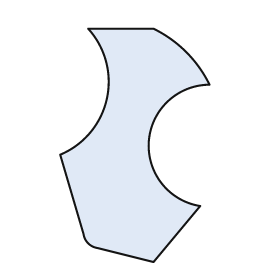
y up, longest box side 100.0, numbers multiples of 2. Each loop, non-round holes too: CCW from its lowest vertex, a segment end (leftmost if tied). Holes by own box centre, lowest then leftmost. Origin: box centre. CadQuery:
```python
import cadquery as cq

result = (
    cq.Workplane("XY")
    .moveTo(8.0, -50.0)
    .lineTo(28.0, -26.0)
    .threePointArc((6.0, 2.0), (32.0, 26.0))
    .threePointArc((22.0, 40.0), (8.0, 50.0))
    .lineTo(-20.0, 50.0)
    .threePointArc((-12.0, 20.0), (-32.0, -4.0))
    .lineTo(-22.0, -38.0)
    .threePointArc((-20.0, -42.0), (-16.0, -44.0))
    .close()
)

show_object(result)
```